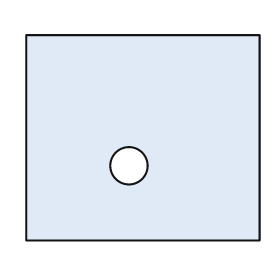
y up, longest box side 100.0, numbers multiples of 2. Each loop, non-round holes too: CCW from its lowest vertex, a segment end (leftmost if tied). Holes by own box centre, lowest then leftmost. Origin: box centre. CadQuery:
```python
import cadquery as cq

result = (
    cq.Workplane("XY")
    .moveTo(-50.0, -44.0)
    .lineTo(50.0, -44.0)
    .lineTo(50.0, 44.0)
    .lineTo(-50.0, 44.0)
    .close()
    .moveTo(-6.0, -12.0)
    .circle(8.0)
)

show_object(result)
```